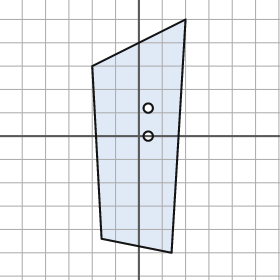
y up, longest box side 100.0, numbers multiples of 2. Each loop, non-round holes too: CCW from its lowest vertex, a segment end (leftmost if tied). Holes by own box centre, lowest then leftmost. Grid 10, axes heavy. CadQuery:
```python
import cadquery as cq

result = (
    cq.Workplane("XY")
    .moveTo(14.0, -50.0)
    .lineTo(20.0, 50.0)
    .lineTo(-20.0, 30.0)
    .lineTo(-16.0, -44.0)
    .close()
    .moveTo(4.0, 0.0)
    .circle(2.0)
    .moveTo(4.0, 12.0)
    .circle(2.0)
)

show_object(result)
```